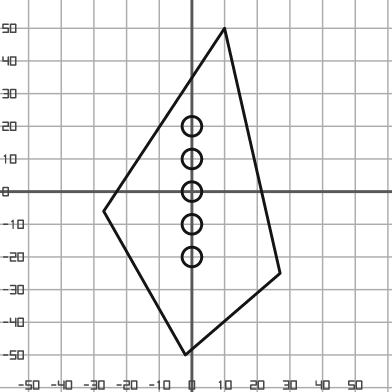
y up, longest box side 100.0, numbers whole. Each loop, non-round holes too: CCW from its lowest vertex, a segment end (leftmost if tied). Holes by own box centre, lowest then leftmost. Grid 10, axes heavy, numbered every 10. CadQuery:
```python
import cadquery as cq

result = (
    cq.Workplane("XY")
    .moveTo(-2.0, -50.0)
    .lineTo(27.0, -25.0)
    .lineTo(10.0, 50.0)
    .lineTo(-27.0, -6.0)
    .close()
    .moveTo(0.0, -20.0)
    .circle(3.0)
    .moveTo(0.0, -10.0)
    .circle(3.0)
    .moveTo(0.0, 0.0)
    .circle(3.0)
    .moveTo(0.0, 10.0)
    .circle(3.0)
    .moveTo(0.0, 20.0)
    .circle(3.0)
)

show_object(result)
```